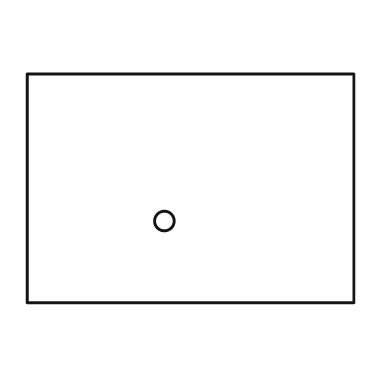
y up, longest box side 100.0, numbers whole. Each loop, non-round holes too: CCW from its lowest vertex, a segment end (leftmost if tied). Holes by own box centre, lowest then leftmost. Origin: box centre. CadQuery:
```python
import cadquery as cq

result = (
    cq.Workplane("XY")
    .moveTo(-50.0, -35.0)
    .lineTo(50.0, -35.0)
    .lineTo(50.0, 35.0)
    .lineTo(-50.0, 35.0)
    .close()
    .moveTo(-8.0, -10.0)
    .circle(3.0)
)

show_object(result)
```